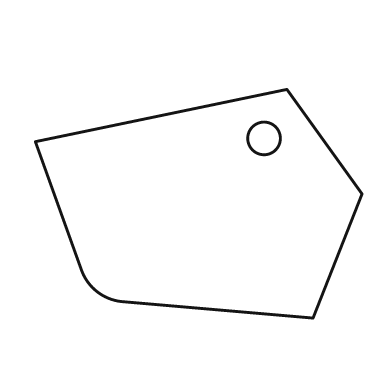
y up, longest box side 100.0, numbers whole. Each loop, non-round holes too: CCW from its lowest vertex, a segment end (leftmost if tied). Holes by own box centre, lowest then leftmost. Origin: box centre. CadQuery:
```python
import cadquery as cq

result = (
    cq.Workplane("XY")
    .moveTo(35.0, -35.0)
    .lineTo(50.0, 3.0)
    .lineTo(27.0, 35.0)
    .lineTo(-50.0, 19.0)
    .lineTo(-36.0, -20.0)
    .threePointArc((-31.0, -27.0), (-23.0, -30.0))
    .close()
    .moveTo(20.0, 20.0)
    .circle(5.0)
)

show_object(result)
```